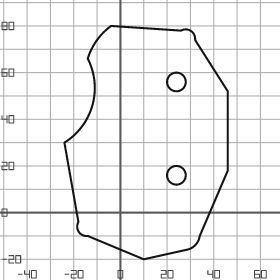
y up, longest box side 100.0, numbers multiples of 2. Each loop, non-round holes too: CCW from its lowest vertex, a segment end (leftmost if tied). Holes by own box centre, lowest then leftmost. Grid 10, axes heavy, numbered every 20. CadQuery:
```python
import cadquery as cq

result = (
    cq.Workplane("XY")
    .moveTo(10.0, -20.0)
    .lineTo(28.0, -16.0)
    .threePointArc((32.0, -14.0), (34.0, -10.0))
    .lineTo(46.0, 18.0)
    .lineTo(46.0, 52.0)
    .lineTo(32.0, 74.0)
    .threePointArc((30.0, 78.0), (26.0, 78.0))
    .lineTo(-4.0, 80.0)
    .threePointArc((-10.0, 74.0), (-14.0, 66.0))
    .threePointArc((-12.0, 46.0), (-24.0, 30.0))
    .lineTo(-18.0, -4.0)
    .threePointArc((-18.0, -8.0), (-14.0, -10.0))
    .close()
    .moveTo(24.0, 16.0)
    .circle(4.0)
    .moveTo(24.0, 56.0)
    .circle(4.0)
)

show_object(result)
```